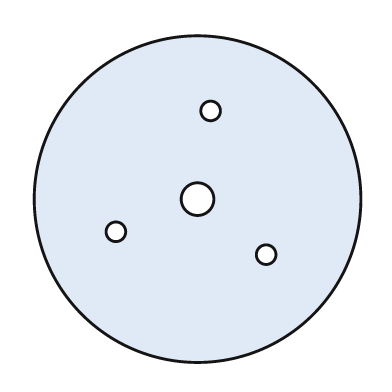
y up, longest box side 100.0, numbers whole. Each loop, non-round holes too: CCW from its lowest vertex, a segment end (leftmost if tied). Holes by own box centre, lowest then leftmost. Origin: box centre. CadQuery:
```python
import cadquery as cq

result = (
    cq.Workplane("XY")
    .moveTo(0.0, 0.0)
    .circle(50.0)
    .moveTo(21.0, -17.0)
    .circle(3.0)
    .moveTo(-25.0, -10.0)
    .circle(3.0)
    .moveTo(0.0, 0.0)
    .circle(5.0)
    .moveTo(4.0, 27.0)
    .circle(3.0)
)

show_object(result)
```